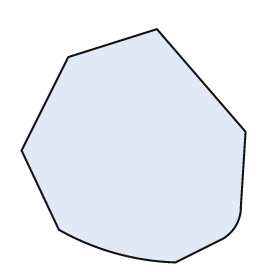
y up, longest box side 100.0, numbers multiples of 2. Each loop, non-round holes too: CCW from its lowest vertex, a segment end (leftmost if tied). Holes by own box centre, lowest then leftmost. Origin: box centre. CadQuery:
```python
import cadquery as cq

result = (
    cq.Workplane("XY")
    .moveTo(18.0, -50.0)
    .lineTo(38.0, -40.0)
    .threePointArc((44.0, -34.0), (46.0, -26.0))
    .lineTo(48.0, 6.0)
    .lineTo(10.0, 50.0)
    .lineTo(-28.0, 38.0)
    .lineTo(-48.0, -2.0)
    .lineTo(-32.0, -36.0)
    .threePointArc((-8.0, -46.0), (18.0, -50.0))
    .close()
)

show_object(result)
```